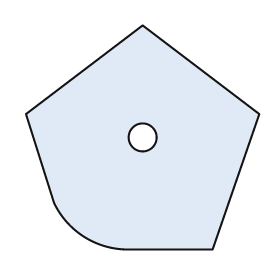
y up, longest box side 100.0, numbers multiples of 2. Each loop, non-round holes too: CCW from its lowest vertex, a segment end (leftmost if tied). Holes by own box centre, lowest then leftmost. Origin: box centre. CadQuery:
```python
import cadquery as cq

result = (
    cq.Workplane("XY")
    .moveTo(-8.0, -48.0)
    .lineTo(30.0, -48.0)
    .lineTo(50.0, 10.0)
    .lineTo(0.0, 48.0)
    .lineTo(-50.0, 10.0)
    .lineTo(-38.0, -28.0)
    .threePointArc((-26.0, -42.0), (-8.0, -48.0))
    .close()
    .moveTo(0.0, 0.0)
    .circle(6.0)
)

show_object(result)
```